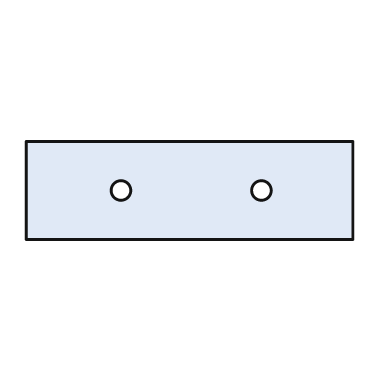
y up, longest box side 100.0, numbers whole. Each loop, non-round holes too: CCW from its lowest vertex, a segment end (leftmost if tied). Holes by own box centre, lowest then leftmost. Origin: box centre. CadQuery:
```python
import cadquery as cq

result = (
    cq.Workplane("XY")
    .moveTo(-50.0, -15.0)
    .lineTo(50.0, -15.0)
    .lineTo(50.0, 15.0)
    .lineTo(-50.0, 15.0)
    .close()
    .moveTo(-21.0, 0.0)
    .circle(3.0)
    .moveTo(22.0, 0.0)
    .circle(3.0)
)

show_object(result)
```